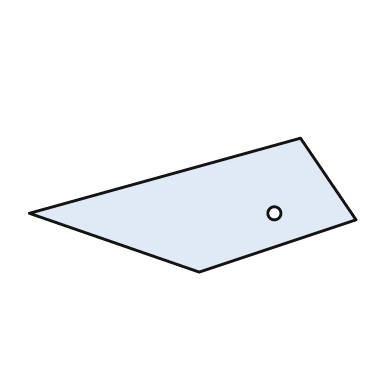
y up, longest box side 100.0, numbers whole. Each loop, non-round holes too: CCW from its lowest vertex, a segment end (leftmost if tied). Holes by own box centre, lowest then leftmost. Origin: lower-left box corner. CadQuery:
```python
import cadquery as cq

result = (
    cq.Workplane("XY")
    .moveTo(52.0, 0.0)
    .lineTo(100.0, 16.0)
    .lineTo(83.0, 41.0)
    .lineTo(0.0, 18.0)
    .close()
    .moveTo(75.0, 18.0)
    .circle(2.0)
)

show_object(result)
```